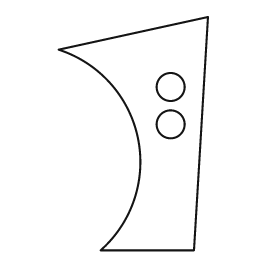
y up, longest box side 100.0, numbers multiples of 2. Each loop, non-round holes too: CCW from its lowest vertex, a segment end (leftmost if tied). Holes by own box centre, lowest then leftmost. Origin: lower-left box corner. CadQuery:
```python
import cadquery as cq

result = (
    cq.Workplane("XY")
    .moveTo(18.0, 0.0)
    .lineTo(58.0, 0.0)
    .lineTo(64.0, 100.0)
    .lineTo(0.0, 86.0)
    .threePointArc((34.0, 48.0), (18.0, 0.0))
    .close()
    .moveTo(48.0, 54.0)
    .circle(6.0)
    .moveTo(48.0, 70.0)
    .circle(6.0)
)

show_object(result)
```